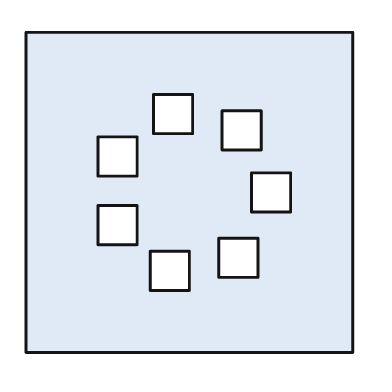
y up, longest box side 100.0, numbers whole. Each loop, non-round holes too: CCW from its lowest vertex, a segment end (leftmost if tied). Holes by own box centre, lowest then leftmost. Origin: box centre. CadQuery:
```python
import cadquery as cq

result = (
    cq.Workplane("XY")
    .moveTo(-50.0, -49.0)
    .lineTo(50.0, -49.0)
    .lineTo(50.0, 49.0)
    .lineTo(-50.0, 49.0)
    .close()
    .moveTo(-12.0, -30.0)
    .lineTo(0.0, -30.0)
    .lineTo(0.0, -18.0)
    .lineTo(-12.0, -18.0)
    .close()
    .moveTo(9.0, -26.0)
    .lineTo(21.0, -26.0)
    .lineTo(21.0, -14.0)
    .lineTo(9.0, -14.0)
    .close()
    .moveTo(-28.0, -16.0)
    .lineTo(-16.0, -16.0)
    .lineTo(-16.0, -4.0)
    .lineTo(-28.0, -4.0)
    .close()
    .moveTo(19.0, -6.0)
    .lineTo(31.0, -6.0)
    .lineTo(31.0, 6.0)
    .lineTo(19.0, 6.0)
    .close()
    .moveTo(-28.0, 5.0)
    .lineTo(-16.0, 5.0)
    .lineTo(-16.0, 17.0)
    .lineTo(-28.0, 17.0)
    .close()
    .moveTo(10.0, 13.0)
    .lineTo(22.0, 13.0)
    .lineTo(22.0, 25.0)
    .lineTo(10.0, 25.0)
    .close()
    .moveTo(-11.0, 18.0)
    .lineTo(1.0, 18.0)
    .lineTo(1.0, 30.0)
    .lineTo(-11.0, 30.0)
    .close()
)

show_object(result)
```